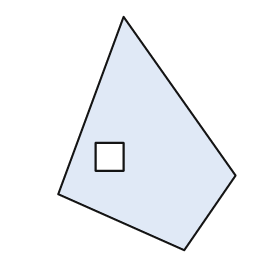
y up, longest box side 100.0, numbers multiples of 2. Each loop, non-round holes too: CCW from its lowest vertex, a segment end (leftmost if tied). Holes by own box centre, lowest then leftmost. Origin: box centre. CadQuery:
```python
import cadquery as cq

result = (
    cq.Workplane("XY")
    .moveTo(16.0, -50.0)
    .lineTo(38.0, -18.0)
    .lineTo(-10.0, 50.0)
    .lineTo(-38.0, -26.0)
    .close()
    .moveTo(-22.0, -16.0)
    .lineTo(-10.0, -16.0)
    .lineTo(-10.0, -4.0)
    .lineTo(-22.0, -4.0)
    .close()
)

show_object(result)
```